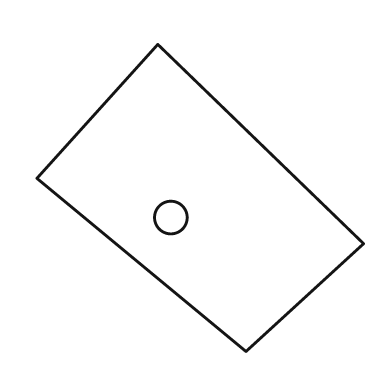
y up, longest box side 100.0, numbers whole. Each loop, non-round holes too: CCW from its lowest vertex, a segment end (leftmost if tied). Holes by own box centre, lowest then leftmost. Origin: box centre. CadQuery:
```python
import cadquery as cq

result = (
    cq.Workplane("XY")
    .moveTo(14.0, -47.0)
    .lineTo(50.0, -14.0)
    .lineTo(-13.0, 47.0)
    .lineTo(-50.0, 6.0)
    .close()
    .moveTo(-9.0, -6.0)
    .circle(5.0)
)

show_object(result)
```